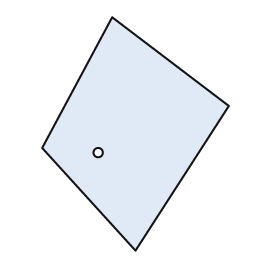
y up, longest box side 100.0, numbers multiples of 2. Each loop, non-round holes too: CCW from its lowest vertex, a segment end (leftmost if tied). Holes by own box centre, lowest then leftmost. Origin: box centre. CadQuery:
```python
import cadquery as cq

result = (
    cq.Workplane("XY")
    .moveTo(0.0, -50.0)
    .lineTo(40.0, 12.0)
    .lineTo(-10.0, 50.0)
    .lineTo(-40.0, -6.0)
    .close()
    .moveTo(-16.0, -8.0)
    .circle(2.0)
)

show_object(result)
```